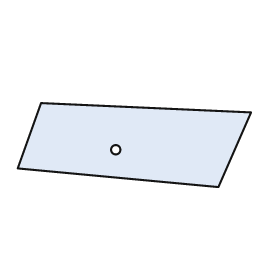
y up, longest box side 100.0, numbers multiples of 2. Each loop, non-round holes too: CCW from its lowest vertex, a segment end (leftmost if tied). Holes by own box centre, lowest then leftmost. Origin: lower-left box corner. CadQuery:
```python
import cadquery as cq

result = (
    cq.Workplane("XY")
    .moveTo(86.0, 0.0)
    .lineTo(100.0, 32.0)
    .lineTo(10.0, 36.0)
    .lineTo(0.0, 8.0)
    .close()
    .moveTo(42.0, 16.0)
    .circle(2.0)
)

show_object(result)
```